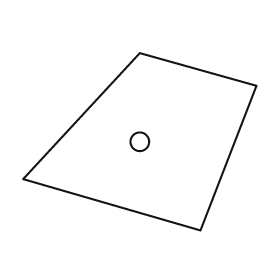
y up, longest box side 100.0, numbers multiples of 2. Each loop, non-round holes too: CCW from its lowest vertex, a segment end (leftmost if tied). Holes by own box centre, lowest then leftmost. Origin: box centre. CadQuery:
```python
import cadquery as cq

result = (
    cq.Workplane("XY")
    .moveTo(26.0, -38.0)
    .lineTo(50.0, 24.0)
    .lineTo(0.0, 38.0)
    .lineTo(-50.0, -16.0)
    .close()
    .moveTo(0.0, 0.0)
    .circle(4.0)
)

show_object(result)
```